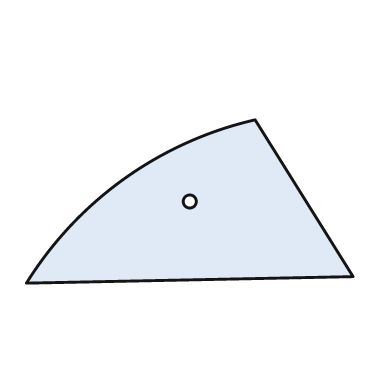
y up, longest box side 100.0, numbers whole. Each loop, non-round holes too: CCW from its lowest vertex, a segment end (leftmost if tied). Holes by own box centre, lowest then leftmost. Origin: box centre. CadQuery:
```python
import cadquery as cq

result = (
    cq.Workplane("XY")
    .moveTo(-50.0, -25.0)
    .lineTo(50.0, -23.0)
    .lineTo(20.0, 25.0)
    .threePointArc((-20.0, 7.0), (-50.0, -25.0))
    .close()
    .moveTo(0.0, 0.0)
    .circle(2.0)
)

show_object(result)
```